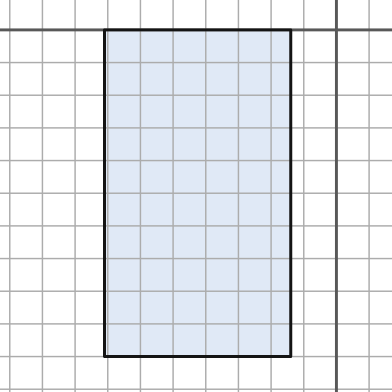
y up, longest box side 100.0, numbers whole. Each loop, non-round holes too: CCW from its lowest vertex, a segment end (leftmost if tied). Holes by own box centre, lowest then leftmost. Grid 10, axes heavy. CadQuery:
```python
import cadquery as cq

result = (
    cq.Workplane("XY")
    .moveTo(-71.0, -100.0)
    .lineTo(-14.0, -100.0)
    .lineTo(-14.0, 0.0)
    .lineTo(-71.0, 0.0)
    .close()
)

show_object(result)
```